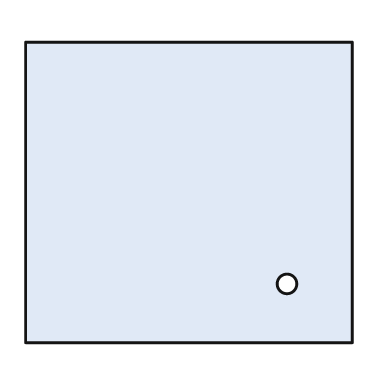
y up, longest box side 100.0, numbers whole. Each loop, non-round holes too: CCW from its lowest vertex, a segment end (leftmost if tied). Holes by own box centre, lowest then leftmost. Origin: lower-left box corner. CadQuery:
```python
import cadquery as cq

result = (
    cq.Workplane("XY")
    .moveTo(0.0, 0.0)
    .lineTo(100.0, 0.0)
    .lineTo(100.0, 92.0)
    .lineTo(0.0, 92.0)
    .close()
    .moveTo(80.0, 18.0)
    .circle(3.0)
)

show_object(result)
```